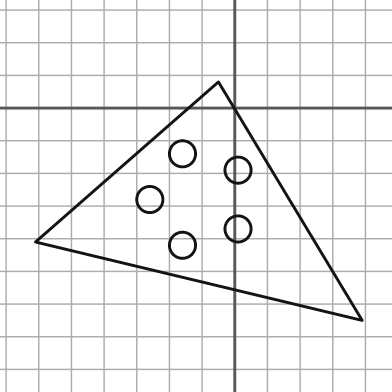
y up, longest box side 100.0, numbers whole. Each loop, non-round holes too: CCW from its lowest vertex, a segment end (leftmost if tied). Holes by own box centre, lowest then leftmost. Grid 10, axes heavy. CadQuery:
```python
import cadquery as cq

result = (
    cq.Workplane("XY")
    .moveTo(39.0, -65.0)
    .lineTo(-5.0, 8.0)
    .lineTo(-61.0, -41.0)
    .close()
    .moveTo(-16.0, -42.0)
    .circle(4.0)
    .moveTo(1.0, -37.0)
    .circle(4.0)
    .moveTo(-26.0, -28.0)
    .circle(4.0)
    .moveTo(1.0, -19.0)
    .circle(4.0)
    .moveTo(-16.0, -14.0)
    .circle(4.0)
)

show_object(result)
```